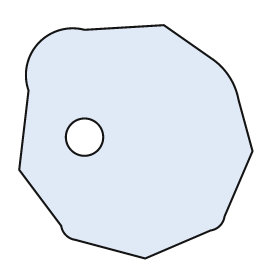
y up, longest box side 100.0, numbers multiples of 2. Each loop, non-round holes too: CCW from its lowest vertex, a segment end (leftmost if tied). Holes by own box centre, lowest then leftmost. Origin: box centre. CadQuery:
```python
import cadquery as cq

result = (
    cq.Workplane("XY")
    .moveTo(4.0, -50.0)
    .lineTo(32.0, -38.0)
    .threePointArc((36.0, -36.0), (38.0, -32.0))
    .lineTo(50.0, -4.0)
    .lineTo(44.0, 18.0)
    .threePointArc((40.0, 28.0), (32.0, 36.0))
    .lineTo(12.0, 50.0)
    .lineTo(-22.0, 48.0)
    .threePointArc((-42.0, 42.0), (-46.0, 22.0))
    .lineTo(-50.0, -12.0)
    .lineTo(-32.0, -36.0)
    .threePointArc((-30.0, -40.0), (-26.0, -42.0))
    .close()
    .moveTo(-22.0, 2.0)
    .circle(8.0)
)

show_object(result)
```